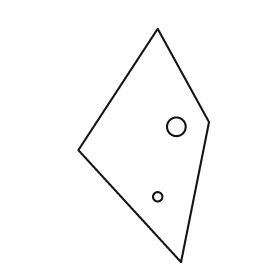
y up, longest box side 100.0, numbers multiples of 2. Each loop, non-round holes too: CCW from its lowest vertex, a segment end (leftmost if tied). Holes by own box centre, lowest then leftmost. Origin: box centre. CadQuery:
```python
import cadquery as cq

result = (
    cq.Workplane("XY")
    .moveTo(16.0, -50.0)
    .lineTo(28.0, 10.0)
    .lineTo(6.0, 50.0)
    .lineTo(-28.0, -2.0)
    .close()
    .moveTo(6.0, -22.0)
    .circle(2.0)
    .moveTo(14.0, 8.0)
    .circle(4.0)
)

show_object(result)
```